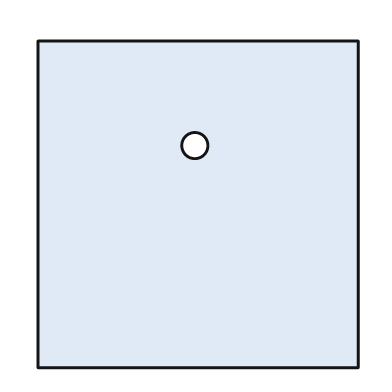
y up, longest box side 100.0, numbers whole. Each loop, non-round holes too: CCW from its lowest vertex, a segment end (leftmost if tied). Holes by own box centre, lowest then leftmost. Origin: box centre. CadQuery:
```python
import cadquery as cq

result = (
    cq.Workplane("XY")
    .moveTo(-49.0, -50.0)
    .lineTo(49.0, -50.0)
    .lineTo(49.0, 50.0)
    .lineTo(-49.0, 50.0)
    .close()
    .moveTo(-1.0, 18.0)
    .circle(4.0)
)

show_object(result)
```